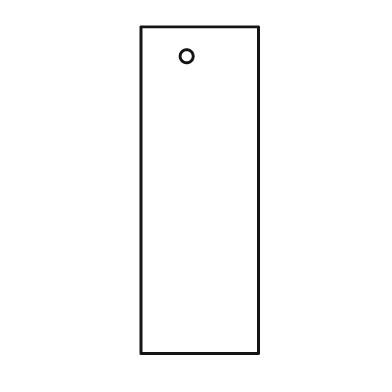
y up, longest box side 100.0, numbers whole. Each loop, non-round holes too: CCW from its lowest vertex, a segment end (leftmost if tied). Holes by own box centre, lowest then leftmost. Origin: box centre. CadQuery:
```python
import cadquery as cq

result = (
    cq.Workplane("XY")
    .moveTo(-18.0, -50.0)
    .lineTo(18.0, -50.0)
    .lineTo(18.0, 50.0)
    .lineTo(-18.0, 50.0)
    .close()
    .moveTo(-4.0, 41.0)
    .circle(2.0)
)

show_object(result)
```